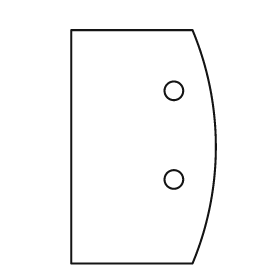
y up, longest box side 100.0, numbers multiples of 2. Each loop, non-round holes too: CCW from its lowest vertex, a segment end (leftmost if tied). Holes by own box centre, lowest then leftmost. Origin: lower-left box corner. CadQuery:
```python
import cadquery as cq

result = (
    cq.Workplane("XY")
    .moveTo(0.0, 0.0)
    .lineTo(52.0, 0.0)
    .threePointArc((62.0, 50.0), (52.0, 100.0))
    .lineTo(0.0, 100.0)
    .close()
    .moveTo(44.0, 36.0)
    .circle(4.0)
    .moveTo(44.0, 74.0)
    .circle(4.0)
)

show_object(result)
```